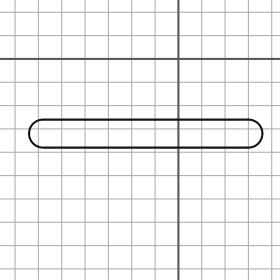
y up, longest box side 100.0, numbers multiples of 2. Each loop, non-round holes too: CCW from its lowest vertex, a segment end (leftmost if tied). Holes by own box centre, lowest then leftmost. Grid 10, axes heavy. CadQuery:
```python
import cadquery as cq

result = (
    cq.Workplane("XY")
    .moveTo(-58.0, -38.0)
    .lineTo(30.0, -38.0)
    .threePointArc((36.0, -32.0), (30.0, -26.0))
    .lineTo(-58.0, -26.0)
    .threePointArc((-64.0, -32.0), (-58.0, -38.0))
    .close()
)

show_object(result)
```